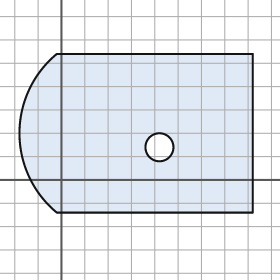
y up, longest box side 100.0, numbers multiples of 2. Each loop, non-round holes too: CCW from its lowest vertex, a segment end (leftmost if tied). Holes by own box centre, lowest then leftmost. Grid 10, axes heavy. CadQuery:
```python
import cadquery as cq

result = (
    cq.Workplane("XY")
    .moveTo(-2.0, -14.0)
    .lineTo(82.0, -14.0)
    .lineTo(82.0, 54.0)
    .lineTo(-2.0, 54.0)
    .threePointArc((-18.0, 20.0), (-2.0, -14.0))
    .close()
    .moveTo(42.0, 14.0)
    .circle(6.0)
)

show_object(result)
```